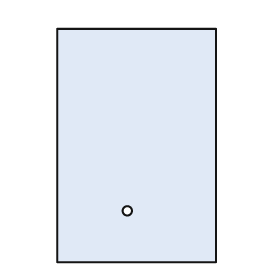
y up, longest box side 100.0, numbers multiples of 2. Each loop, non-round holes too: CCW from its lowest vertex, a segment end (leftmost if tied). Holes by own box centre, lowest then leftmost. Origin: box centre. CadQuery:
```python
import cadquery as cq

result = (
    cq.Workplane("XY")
    .moveTo(-34.0, -50.0)
    .lineTo(34.0, -50.0)
    .lineTo(34.0, 50.0)
    .lineTo(-34.0, 50.0)
    .close()
    .moveTo(-4.0, -28.0)
    .circle(2.0)
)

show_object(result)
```